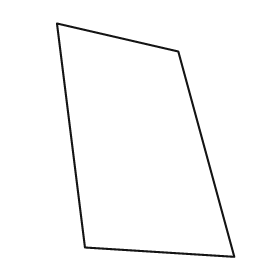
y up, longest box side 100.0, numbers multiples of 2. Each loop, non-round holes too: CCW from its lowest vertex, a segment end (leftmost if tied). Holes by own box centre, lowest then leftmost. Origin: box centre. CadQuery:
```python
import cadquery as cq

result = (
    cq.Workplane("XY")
    .moveTo(38.0, -50.0)
    .lineTo(14.0, 38.0)
    .lineTo(-38.0, 50.0)
    .lineTo(-26.0, -46.0)
    .close()
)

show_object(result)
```